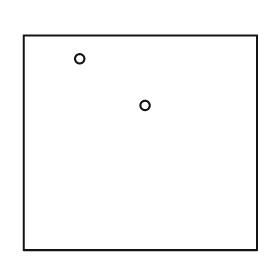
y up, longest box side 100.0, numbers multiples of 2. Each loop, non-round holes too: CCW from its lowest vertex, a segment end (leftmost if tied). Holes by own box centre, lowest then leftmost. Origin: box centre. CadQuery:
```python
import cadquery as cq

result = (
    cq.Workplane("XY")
    .moveTo(-50.0, -46.0)
    .lineTo(50.0, -46.0)
    .lineTo(50.0, 46.0)
    .lineTo(-50.0, 46.0)
    .close()
    .moveTo(2.0, 16.0)
    .circle(2.0)
    .moveTo(-26.0, 36.0)
    .circle(2.0)
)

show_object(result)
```